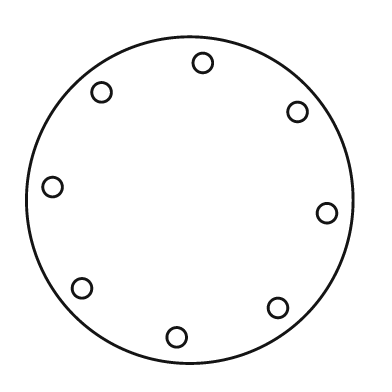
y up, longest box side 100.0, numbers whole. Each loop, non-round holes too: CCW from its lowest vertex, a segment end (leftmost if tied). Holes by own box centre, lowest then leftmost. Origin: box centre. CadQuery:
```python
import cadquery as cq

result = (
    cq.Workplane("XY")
    .moveTo(0.0, 0.0)
    .circle(50.0)
    .moveTo(-4.0, -42.0)
    .circle(3.0)
    .moveTo(27.0, -33.0)
    .circle(3.0)
    .moveTo(-33.0, -27.0)
    .circle(3.0)
    .moveTo(42.0, -4.0)
    .circle(3.0)
    .moveTo(-42.0, 4.0)
    .circle(3.0)
    .moveTo(33.0, 27.0)
    .circle(3.0)
    .moveTo(-27.0, 33.0)
    .circle(3.0)
    .moveTo(4.0, 42.0)
    .circle(3.0)
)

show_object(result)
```